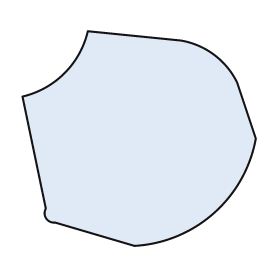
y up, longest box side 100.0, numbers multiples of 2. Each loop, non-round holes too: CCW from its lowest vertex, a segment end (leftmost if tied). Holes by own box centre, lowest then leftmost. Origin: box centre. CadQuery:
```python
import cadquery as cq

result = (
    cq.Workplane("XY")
    .moveTo(-2.0, -46.0)
    .threePointArc((32.0, -32.0), (50.0, 0.0))
    .lineTo(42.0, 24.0)
    .threePointArc((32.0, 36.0), (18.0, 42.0))
    .lineTo(-22.0, 46.0)
    .threePointArc((-32.0, 28.0), (-50.0, 18.0))
    .lineTo(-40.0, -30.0)
    .threePointArc((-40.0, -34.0), (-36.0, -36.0))
    .close()
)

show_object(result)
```